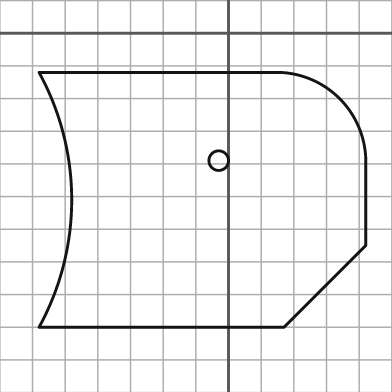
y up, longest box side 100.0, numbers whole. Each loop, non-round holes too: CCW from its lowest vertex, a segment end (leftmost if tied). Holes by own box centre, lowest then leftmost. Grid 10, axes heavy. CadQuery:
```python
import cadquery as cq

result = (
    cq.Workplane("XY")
    .moveTo(-58.0, -90.0)
    .lineTo(17.0, -90.0)
    .lineTo(42.0, -65.0)
    .lineTo(42.0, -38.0)
    .threePointArc((34.0, -20.0), (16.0, -12.0))
    .lineTo(-58.0, -12.0)
    .threePointArc((-48.0, -51.0), (-58.0, -90.0))
    .close()
    .moveTo(-3.0, -39.0)
    .circle(3.0)
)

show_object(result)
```